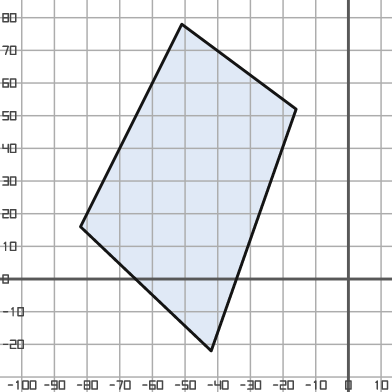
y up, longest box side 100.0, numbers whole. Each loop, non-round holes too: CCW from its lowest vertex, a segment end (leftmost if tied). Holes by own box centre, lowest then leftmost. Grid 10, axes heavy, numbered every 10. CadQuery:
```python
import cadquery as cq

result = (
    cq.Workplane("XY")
    .moveTo(-42.0, -22.0)
    .lineTo(-16.0, 52.0)
    .lineTo(-51.0, 78.0)
    .lineTo(-82.0, 16.0)
    .close()
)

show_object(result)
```